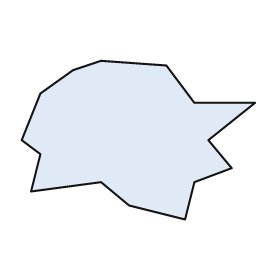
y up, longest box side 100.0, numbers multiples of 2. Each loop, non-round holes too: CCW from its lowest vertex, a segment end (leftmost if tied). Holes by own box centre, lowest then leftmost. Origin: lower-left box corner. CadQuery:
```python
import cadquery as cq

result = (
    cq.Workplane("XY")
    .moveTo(70.0, 0.0)
    .lineTo(74.0, 16.0)
    .lineTo(90.0, 22.0)
    .lineTo(80.0, 34.0)
    .lineTo(100.0, 50.0)
    .lineTo(74.0, 50.0)
    .lineTo(62.0, 66.0)
    .lineTo(34.0, 68.0)
    .lineTo(22.0, 64.0)
    .lineTo(8.0, 54.0)
    .lineTo(0.0, 34.0)
    .lineTo(8.0, 28.0)
    .lineTo(4.0, 12.0)
    .lineTo(34.0, 16.0)
    .lineTo(46.0, 6.0)
    .close()
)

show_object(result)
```